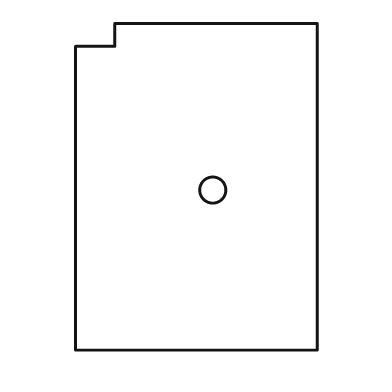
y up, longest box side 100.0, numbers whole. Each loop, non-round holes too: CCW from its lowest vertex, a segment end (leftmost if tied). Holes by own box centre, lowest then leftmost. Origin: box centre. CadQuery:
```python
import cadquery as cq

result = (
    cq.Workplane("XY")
    .moveTo(-37.0, -50.0)
    .lineTo(37.0, -50.0)
    .lineTo(37.0, 50.0)
    .lineTo(-25.0, 50.0)
    .lineTo(-25.0, 43.0)
    .lineTo(-37.0, 43.0)
    .close()
    .moveTo(5.0, -1.0)
    .circle(4.0)
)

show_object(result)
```